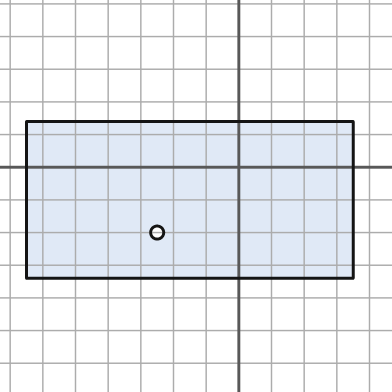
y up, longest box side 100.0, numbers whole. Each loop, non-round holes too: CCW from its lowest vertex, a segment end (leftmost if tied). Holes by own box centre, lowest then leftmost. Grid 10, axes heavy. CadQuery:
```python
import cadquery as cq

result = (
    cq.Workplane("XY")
    .moveTo(-65.0, -34.0)
    .lineTo(35.0, -34.0)
    .lineTo(35.0, 14.0)
    .lineTo(-65.0, 14.0)
    .close()
    .moveTo(-25.0, -20.0)
    .circle(2.0)
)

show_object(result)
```